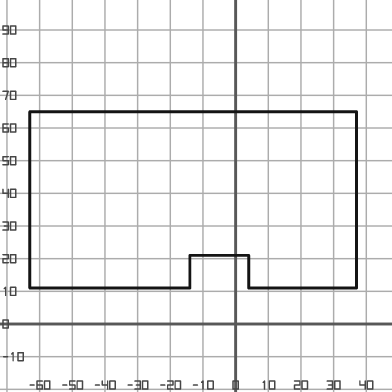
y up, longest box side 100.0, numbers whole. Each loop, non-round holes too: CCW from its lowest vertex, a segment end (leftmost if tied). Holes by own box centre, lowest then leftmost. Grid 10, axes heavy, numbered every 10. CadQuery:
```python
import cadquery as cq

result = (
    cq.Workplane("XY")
    .moveTo(-63.0, 11.0)
    .lineTo(-14.0, 11.0)
    .lineTo(-14.0, 21.0)
    .lineTo(4.0, 21.0)
    .lineTo(4.0, 11.0)
    .lineTo(37.0, 11.0)
    .lineTo(37.0, 65.0)
    .lineTo(-63.0, 65.0)
    .close()
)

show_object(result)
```